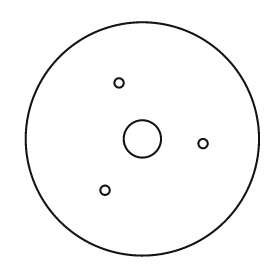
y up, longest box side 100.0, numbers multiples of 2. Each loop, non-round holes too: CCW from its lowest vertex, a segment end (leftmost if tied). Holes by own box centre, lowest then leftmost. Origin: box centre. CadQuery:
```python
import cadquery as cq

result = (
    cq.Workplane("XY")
    .moveTo(0.0, 0.0)
    .circle(50.0)
    .moveTo(-16.0, -22.0)
    .circle(2.0)
    .moveTo(26.0, -2.0)
    .circle(2.0)
    .moveTo(0.0, 0.0)
    .circle(8.0)
    .moveTo(-10.0, 24.0)
    .circle(2.0)
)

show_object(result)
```